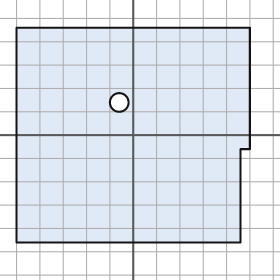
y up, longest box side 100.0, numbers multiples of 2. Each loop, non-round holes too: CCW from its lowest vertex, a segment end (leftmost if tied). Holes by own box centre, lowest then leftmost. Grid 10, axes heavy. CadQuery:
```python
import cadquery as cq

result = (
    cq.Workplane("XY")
    .moveTo(-50.0, -46.0)
    .lineTo(46.0, -46.0)
    .lineTo(46.0, -6.0)
    .lineTo(50.0, -6.0)
    .lineTo(50.0, 46.0)
    .lineTo(-50.0, 46.0)
    .close()
    .moveTo(-6.0, 14.0)
    .circle(4.0)
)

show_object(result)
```